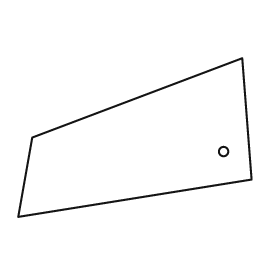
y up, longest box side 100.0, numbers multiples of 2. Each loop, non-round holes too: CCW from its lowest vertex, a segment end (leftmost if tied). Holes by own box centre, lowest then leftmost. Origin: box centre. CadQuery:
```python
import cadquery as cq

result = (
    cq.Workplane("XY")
    .moveTo(-50.0, -34.0)
    .lineTo(50.0, -18.0)
    .lineTo(46.0, 34.0)
    .lineTo(-44.0, 0.0)
    .close()
    .moveTo(38.0, -6.0)
    .circle(2.0)
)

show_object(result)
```